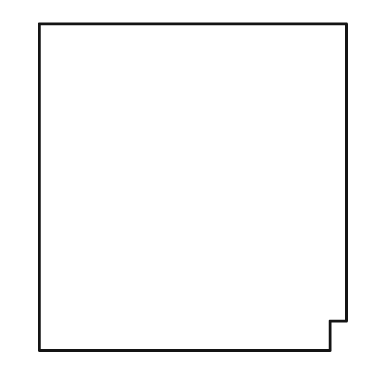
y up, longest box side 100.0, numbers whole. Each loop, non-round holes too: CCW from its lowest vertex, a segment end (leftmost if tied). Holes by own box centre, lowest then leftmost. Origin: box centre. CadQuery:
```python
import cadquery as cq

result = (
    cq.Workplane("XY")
    .moveTo(-47.0, -50.0)
    .lineTo(42.0, -50.0)
    .lineTo(42.0, -41.0)
    .lineTo(47.0, -41.0)
    .lineTo(47.0, 50.0)
    .lineTo(-47.0, 50.0)
    .close()
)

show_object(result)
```